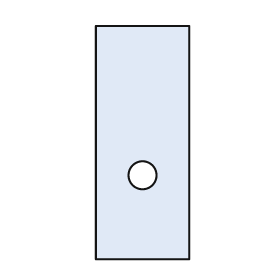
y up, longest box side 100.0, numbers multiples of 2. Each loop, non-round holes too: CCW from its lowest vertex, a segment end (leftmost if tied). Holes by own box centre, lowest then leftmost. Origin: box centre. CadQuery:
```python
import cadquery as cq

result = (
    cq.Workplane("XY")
    .moveTo(-20.0, -50.0)
    .lineTo(20.0, -50.0)
    .lineTo(20.0, 50.0)
    .lineTo(-20.0, 50.0)
    .close()
    .moveTo(0.0, -14.0)
    .circle(6.0)
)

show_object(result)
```